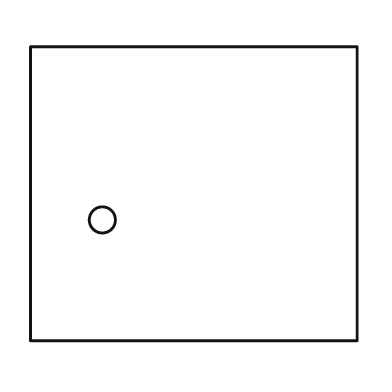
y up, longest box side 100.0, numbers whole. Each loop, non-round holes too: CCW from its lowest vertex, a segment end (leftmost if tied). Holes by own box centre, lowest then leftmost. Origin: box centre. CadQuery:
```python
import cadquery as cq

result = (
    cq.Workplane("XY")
    .moveTo(-50.0, -45.0)
    .lineTo(50.0, -45.0)
    .lineTo(50.0, 45.0)
    .lineTo(-50.0, 45.0)
    .close()
    .moveTo(-28.0, -8.0)
    .circle(4.0)
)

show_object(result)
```